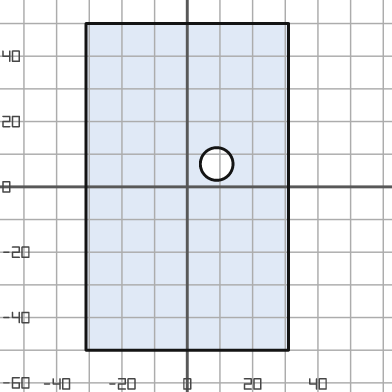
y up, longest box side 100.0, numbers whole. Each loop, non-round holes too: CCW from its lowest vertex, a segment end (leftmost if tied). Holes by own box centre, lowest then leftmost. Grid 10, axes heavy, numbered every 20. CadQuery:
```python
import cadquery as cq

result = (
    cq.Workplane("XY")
    .moveTo(-31.0, -50.0)
    .lineTo(31.0, -50.0)
    .lineTo(31.0, 50.0)
    .lineTo(-31.0, 50.0)
    .close()
    .moveTo(9.0, 7.0)
    .circle(5.0)
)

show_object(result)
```